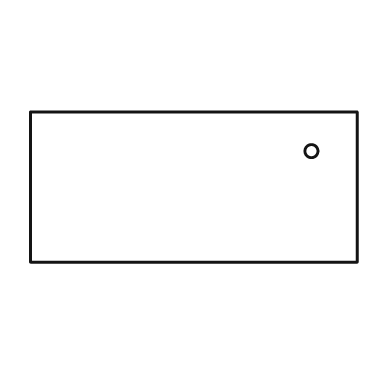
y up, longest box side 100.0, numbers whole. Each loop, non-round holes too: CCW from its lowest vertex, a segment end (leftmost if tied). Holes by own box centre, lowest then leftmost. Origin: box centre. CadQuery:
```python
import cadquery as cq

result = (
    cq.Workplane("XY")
    .moveTo(-50.0, -23.0)
    .lineTo(50.0, -23.0)
    .lineTo(50.0, 23.0)
    .lineTo(-50.0, 23.0)
    .close()
    .moveTo(36.0, 11.0)
    .circle(2.0)
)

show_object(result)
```